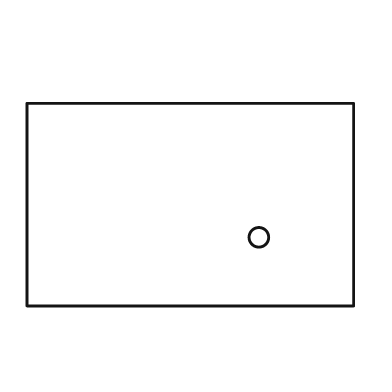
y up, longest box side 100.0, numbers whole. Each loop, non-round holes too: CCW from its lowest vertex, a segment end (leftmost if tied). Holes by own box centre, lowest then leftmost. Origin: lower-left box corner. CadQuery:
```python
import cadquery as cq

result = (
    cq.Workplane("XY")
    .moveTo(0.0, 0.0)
    .lineTo(100.0, 0.0)
    .lineTo(100.0, 62.0)
    .lineTo(0.0, 62.0)
    .close()
    .moveTo(71.0, 21.0)
    .circle(3.0)
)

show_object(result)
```